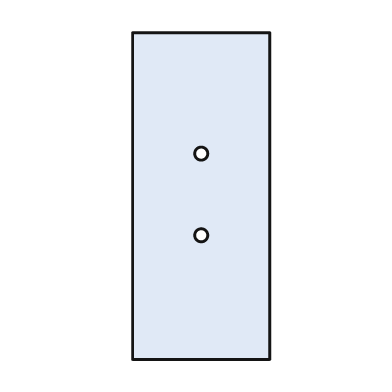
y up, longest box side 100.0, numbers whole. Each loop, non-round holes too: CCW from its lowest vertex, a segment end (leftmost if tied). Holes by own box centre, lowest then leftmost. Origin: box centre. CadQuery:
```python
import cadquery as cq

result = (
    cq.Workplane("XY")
    .moveTo(-21.0, -50.0)
    .lineTo(21.0, -50.0)
    .lineTo(21.0, 50.0)
    .lineTo(-21.0, 50.0)
    .close()
    .moveTo(0.0, -12.0)
    .circle(2.0)
    .moveTo(0.0, 13.0)
    .circle(2.0)
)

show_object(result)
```